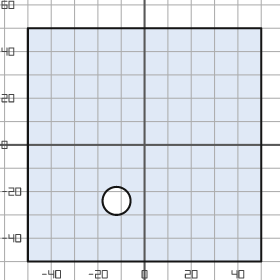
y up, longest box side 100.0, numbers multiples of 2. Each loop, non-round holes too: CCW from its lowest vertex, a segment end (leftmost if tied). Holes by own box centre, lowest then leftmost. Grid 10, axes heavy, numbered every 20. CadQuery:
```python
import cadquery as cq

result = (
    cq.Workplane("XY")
    .moveTo(-50.0, -50.0)
    .lineTo(50.0, -50.0)
    .lineTo(50.0, 50.0)
    .lineTo(-50.0, 50.0)
    .close()
    .moveTo(-12.0, -24.0)
    .circle(6.0)
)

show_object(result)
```